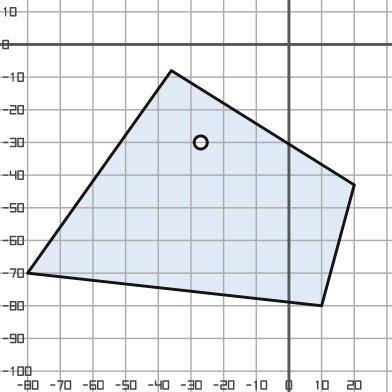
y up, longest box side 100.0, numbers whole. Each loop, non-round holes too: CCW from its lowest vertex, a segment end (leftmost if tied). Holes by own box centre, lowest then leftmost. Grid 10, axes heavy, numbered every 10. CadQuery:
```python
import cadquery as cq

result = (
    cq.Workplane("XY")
    .moveTo(10.0, -80.0)
    .lineTo(20.0, -43.0)
    .lineTo(-36.0, -8.0)
    .lineTo(-80.0, -70.0)
    .close()
    .moveTo(-27.0, -30.0)
    .circle(2.0)
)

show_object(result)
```